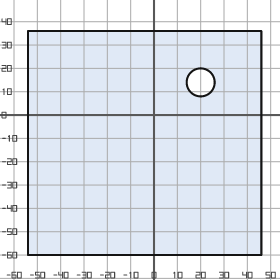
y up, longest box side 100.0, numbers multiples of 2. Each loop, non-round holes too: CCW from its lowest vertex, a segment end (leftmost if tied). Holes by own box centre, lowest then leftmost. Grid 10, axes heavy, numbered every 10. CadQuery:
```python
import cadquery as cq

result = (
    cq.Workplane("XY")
    .moveTo(-54.0, -60.0)
    .lineTo(46.0, -60.0)
    .lineTo(46.0, 36.0)
    .lineTo(-54.0, 36.0)
    .close()
    .moveTo(20.0, 14.0)
    .circle(6.0)
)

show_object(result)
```